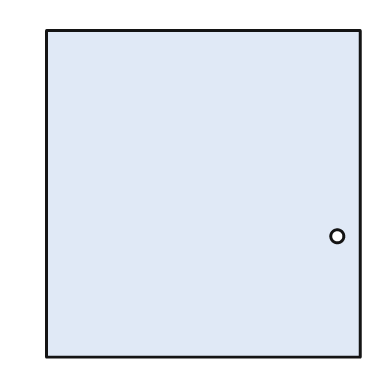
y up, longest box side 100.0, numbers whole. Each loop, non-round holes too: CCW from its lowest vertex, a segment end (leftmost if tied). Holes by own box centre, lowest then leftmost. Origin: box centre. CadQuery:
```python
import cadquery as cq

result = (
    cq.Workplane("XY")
    .moveTo(-48.0, -50.0)
    .lineTo(48.0, -50.0)
    .lineTo(48.0, 50.0)
    .lineTo(-48.0, 50.0)
    .close()
    .moveTo(41.0, -13.0)
    .circle(2.0)
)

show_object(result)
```